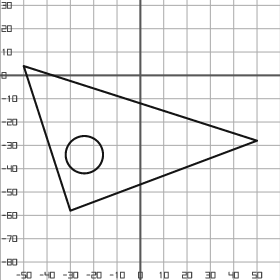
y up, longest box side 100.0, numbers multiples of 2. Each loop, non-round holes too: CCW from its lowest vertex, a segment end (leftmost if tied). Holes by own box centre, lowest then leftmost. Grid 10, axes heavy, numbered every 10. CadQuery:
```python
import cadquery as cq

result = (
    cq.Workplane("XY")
    .moveTo(-30.0, -58.0)
    .lineTo(50.0, -28.0)
    .lineTo(-50.0, 4.0)
    .close()
    .moveTo(-24.0, -34.0)
    .circle(8.0)
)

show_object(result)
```